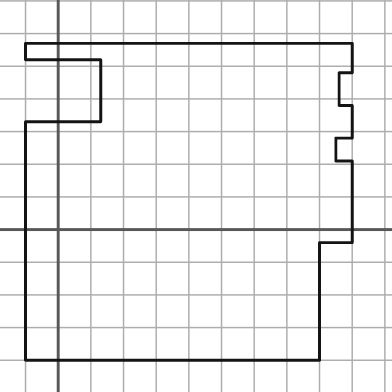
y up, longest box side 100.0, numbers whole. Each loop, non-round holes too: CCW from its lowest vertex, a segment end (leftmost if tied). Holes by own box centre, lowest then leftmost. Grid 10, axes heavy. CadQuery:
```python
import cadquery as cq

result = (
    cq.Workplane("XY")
    .moveTo(-10.0, -40.0)
    .lineTo(80.0, -40.0)
    .lineTo(80.0, -4.0)
    .lineTo(90.0, -4.0)
    .lineTo(90.0, 21.0)
    .lineTo(85.0, 21.0)
    .lineTo(85.0, 28.0)
    .lineTo(90.0, 28.0)
    .lineTo(90.0, 38.0)
    .lineTo(86.0, 38.0)
    .lineTo(86.0, 48.0)
    .lineTo(90.0, 48.0)
    .lineTo(90.0, 57.0)
    .lineTo(-10.0, 57.0)
    .lineTo(-10.0, 52.0)
    .lineTo(13.0, 52.0)
    .lineTo(13.0, 33.0)
    .lineTo(-10.0, 33.0)
    .close()
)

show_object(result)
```